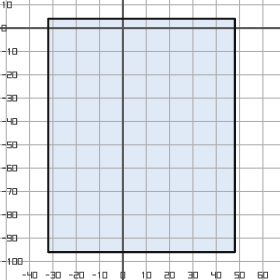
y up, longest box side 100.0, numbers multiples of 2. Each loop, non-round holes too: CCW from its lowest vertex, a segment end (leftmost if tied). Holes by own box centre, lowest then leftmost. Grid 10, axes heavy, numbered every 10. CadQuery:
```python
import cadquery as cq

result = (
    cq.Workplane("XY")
    .moveTo(-32.0, -96.0)
    .lineTo(48.0, -96.0)
    .lineTo(48.0, 4.0)
    .lineTo(-32.0, 4.0)
    .close()
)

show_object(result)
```